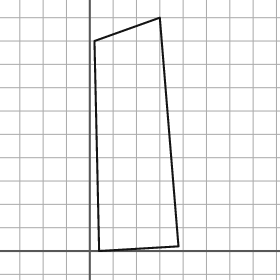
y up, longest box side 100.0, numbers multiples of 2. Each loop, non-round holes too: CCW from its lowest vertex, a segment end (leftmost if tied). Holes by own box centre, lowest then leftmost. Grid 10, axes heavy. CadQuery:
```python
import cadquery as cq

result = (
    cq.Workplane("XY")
    .moveTo(4.0, 0.0)
    .lineTo(38.0, 2.0)
    .lineTo(30.0, 100.0)
    .lineTo(2.0, 90.0)
    .close()
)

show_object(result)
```